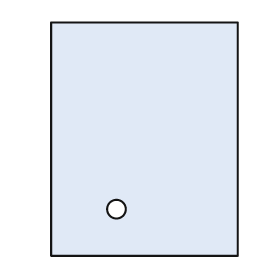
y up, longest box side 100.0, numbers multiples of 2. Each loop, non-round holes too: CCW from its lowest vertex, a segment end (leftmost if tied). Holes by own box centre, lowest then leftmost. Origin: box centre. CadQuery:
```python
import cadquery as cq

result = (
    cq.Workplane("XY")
    .moveTo(-40.0, -50.0)
    .lineTo(40.0, -50.0)
    .lineTo(40.0, 50.0)
    .lineTo(-40.0, 50.0)
    .close()
    .moveTo(-12.0, -30.0)
    .circle(4.0)
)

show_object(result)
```